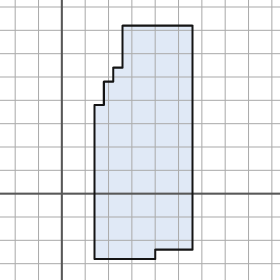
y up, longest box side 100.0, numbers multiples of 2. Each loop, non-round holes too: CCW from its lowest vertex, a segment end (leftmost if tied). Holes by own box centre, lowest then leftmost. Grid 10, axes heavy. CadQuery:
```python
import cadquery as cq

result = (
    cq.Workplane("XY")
    .moveTo(14.0, -28.0)
    .lineTo(40.0, -28.0)
    .lineTo(40.0, -24.0)
    .lineTo(56.0, -24.0)
    .lineTo(56.0, 72.0)
    .lineTo(26.0, 72.0)
    .lineTo(26.0, 54.0)
    .lineTo(22.0, 54.0)
    .lineTo(22.0, 48.0)
    .lineTo(18.0, 48.0)
    .lineTo(18.0, 38.0)
    .lineTo(14.0, 38.0)
    .close()
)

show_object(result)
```